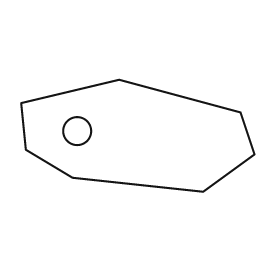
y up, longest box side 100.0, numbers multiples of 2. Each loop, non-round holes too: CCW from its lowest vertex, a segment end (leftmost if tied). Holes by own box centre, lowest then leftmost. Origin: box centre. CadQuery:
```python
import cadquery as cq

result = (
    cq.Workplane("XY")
    .moveTo(28.0, -24.0)
    .lineTo(50.0, -8.0)
    .lineTo(44.0, 10.0)
    .lineTo(-8.0, 24.0)
    .lineTo(-50.0, 14.0)
    .lineTo(-48.0, -6.0)
    .lineTo(-28.0, -18.0)
    .close()
    .moveTo(-26.0, 2.0)
    .circle(6.0)
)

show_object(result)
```